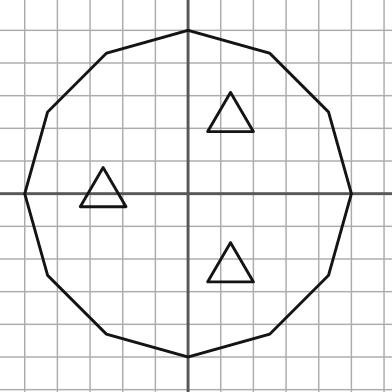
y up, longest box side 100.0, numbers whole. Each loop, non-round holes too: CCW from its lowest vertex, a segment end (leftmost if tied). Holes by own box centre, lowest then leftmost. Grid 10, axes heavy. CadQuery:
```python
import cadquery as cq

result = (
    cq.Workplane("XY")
    .moveTo(0.0, -50.0)
    .lineTo(25.0, -43.0)
    .lineTo(43.0, -25.0)
    .lineTo(50.0, 0.0)
    .lineTo(43.0, 25.0)
    .lineTo(25.0, 43.0)
    .lineTo(0.0, 50.0)
    .lineTo(-25.0, 43.0)
    .lineTo(-43.0, 25.0)
    .lineTo(-50.0, 0.0)
    .lineTo(-43.0, -25.0)
    .lineTo(-25.0, -43.0)
    .close()
    .moveTo(6.0, -27.0)
    .lineTo(20.0, -27.0)
    .lineTo(13.0, -15.0)
    .close()
    .moveTo(-33.0, -4.0)
    .lineTo(-19.0, -4.0)
    .lineTo(-26.0, 8.0)
    .close()
    .moveTo(6.0, 19.0)
    .lineTo(20.0, 19.0)
    .lineTo(13.0, 31.0)
    .close()
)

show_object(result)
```